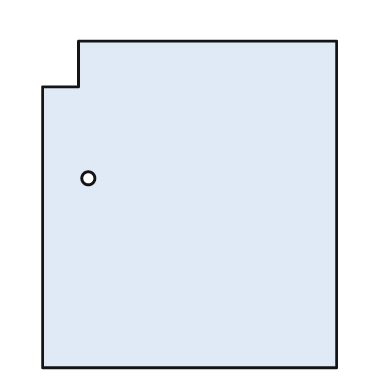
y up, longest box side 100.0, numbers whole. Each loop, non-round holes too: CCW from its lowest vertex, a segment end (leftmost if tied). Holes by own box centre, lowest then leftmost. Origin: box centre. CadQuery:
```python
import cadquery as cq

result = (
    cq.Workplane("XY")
    .moveTo(-45.0, -50.0)
    .lineTo(45.0, -50.0)
    .lineTo(45.0, 50.0)
    .lineTo(-34.0, 50.0)
    .lineTo(-34.0, 36.0)
    .lineTo(-45.0, 36.0)
    .close()
    .moveTo(-31.0, 8.0)
    .circle(2.0)
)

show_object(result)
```